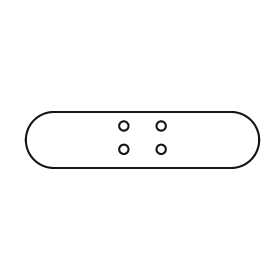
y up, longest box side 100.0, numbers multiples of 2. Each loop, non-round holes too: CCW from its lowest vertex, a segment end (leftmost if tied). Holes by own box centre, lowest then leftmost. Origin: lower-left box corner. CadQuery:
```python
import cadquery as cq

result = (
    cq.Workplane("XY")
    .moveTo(12.0, 0.0)
    .lineTo(88.0, 0.0)
    .threePointArc((100.0, 12.0), (88.0, 24.0))
    .lineTo(12.0, 24.0)
    .threePointArc((0.0, 12.0), (12.0, 0.0))
    .close()
    .moveTo(42.0, 8.0)
    .circle(2.0)
    .moveTo(58.0, 8.0)
    .circle(2.0)
    .moveTo(42.0, 18.0)
    .circle(2.0)
    .moveTo(58.0, 18.0)
    .circle(2.0)
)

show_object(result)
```